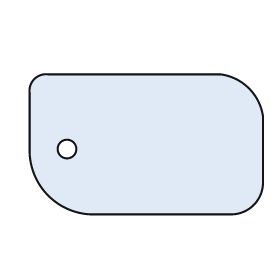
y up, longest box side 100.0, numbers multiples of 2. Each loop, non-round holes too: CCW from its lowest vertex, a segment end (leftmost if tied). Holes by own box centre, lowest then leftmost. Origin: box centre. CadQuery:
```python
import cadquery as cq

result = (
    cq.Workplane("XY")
    .moveTo(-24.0, -30.0)
    .lineTo(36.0, -30.0)
    .threePointArc((46.0, -26.0), (50.0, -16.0))
    .lineTo(50.0, 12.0)
    .threePointArc((44.0, 24.0), (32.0, 30.0))
    .lineTo(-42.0, 30.0)
    .threePointArc((-48.0, 28.0), (-50.0, 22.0))
    .lineTo(-50.0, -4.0)
    .threePointArc((-42.0, -22.0), (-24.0, -30.0))
    .close()
    .moveTo(-34.0, -2.0)
    .circle(4.0)
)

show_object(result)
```